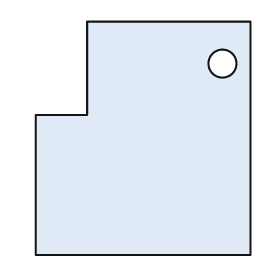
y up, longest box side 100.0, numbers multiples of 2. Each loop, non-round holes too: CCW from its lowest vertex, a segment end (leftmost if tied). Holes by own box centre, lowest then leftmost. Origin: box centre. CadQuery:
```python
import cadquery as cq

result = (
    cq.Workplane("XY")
    .moveTo(-46.0, -50.0)
    .lineTo(46.0, -50.0)
    .lineTo(46.0, 50.0)
    .lineTo(-24.0, 50.0)
    .lineTo(-24.0, 10.0)
    .lineTo(-46.0, 10.0)
    .close()
    .moveTo(34.0, 32.0)
    .circle(6.0)
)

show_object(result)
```